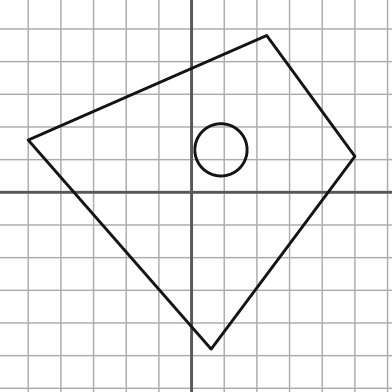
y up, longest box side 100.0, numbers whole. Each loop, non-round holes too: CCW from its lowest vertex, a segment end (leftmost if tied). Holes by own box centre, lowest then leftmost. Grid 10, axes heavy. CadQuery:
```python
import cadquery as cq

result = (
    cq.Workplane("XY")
    .moveTo(6.0, -48.0)
    .lineTo(50.0, 11.0)
    .lineTo(23.0, 48.0)
    .lineTo(-50.0, 16.0)
    .close()
    .moveTo(9.0, 13.0)
    .circle(8.0)
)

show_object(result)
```